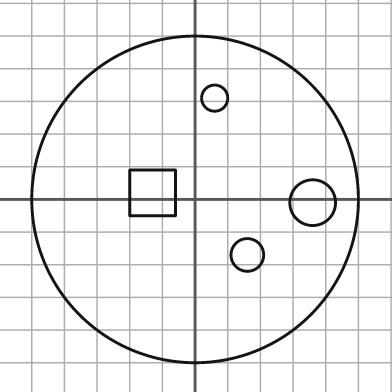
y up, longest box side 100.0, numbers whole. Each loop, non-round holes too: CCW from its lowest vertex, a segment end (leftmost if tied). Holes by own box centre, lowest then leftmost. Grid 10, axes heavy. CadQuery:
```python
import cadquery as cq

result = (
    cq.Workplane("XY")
    .moveTo(0.0, 0.0)
    .circle(50.0)
    .moveTo(16.0, -17.0)
    .circle(5.0)
    .moveTo(36.0, -1.0)
    .circle(7.0)
    .moveTo(-20.0, -5.0)
    .lineTo(-6.0, -5.0)
    .lineTo(-6.0, 9.0)
    .lineTo(-20.0, 9.0)
    .close()
    .moveTo(6.0, 31.0)
    .circle(4.0)
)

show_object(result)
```